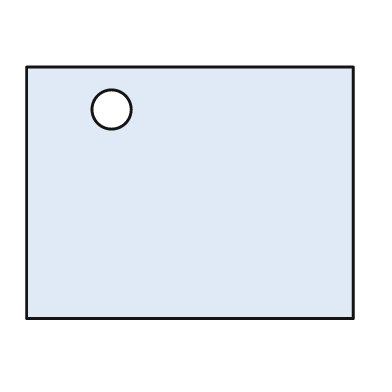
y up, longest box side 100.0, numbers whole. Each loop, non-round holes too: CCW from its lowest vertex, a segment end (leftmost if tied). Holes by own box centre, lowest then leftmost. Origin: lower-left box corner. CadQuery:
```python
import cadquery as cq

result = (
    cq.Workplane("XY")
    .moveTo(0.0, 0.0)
    .lineTo(100.0, 0.0)
    .lineTo(100.0, 77.0)
    .lineTo(0.0, 77.0)
    .close()
    .moveTo(26.0, 64.0)
    .circle(6.0)
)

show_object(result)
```